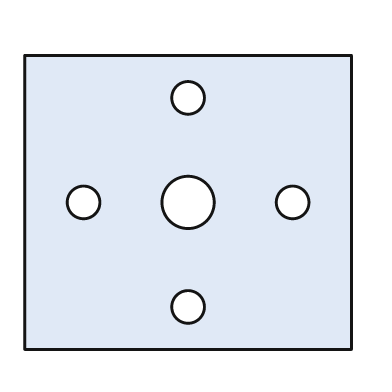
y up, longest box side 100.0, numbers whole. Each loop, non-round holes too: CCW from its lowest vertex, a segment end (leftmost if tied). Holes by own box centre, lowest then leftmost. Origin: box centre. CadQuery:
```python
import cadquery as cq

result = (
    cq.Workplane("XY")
    .moveTo(-50.0, -45.0)
    .lineTo(50.0, -45.0)
    .lineTo(50.0, 45.0)
    .lineTo(-50.0, 45.0)
    .close()
    .moveTo(0.0, -32.0)
    .circle(5.0)
    .moveTo(-32.0, 0.0)
    .circle(5.0)
    .moveTo(0.0, 0.0)
    .circle(8.0)
    .moveTo(32.0, 0.0)
    .circle(5.0)
    .moveTo(0.0, 32.0)
    .circle(5.0)
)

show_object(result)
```